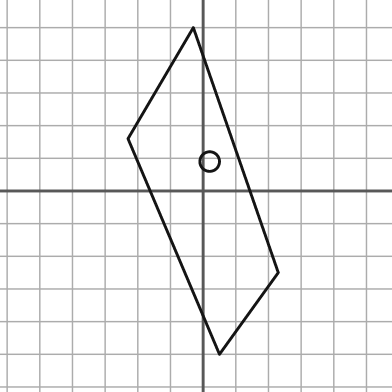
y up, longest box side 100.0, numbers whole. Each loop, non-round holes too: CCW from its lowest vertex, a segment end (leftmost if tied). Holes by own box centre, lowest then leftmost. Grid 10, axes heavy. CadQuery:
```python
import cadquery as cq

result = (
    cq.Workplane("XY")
    .moveTo(5.0, -50.0)
    .lineTo(23.0, -25.0)
    .lineTo(-3.0, 50.0)
    .lineTo(-23.0, 16.0)
    .close()
    .moveTo(2.0, 9.0)
    .circle(3.0)
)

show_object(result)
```